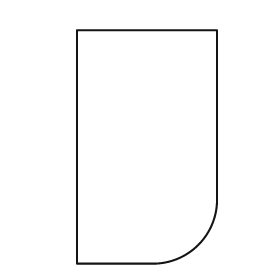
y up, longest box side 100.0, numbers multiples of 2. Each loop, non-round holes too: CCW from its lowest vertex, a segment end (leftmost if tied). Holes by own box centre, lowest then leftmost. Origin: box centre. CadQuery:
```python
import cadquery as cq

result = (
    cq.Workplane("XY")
    .moveTo(-30.0, -50.0)
    .lineTo(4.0, -50.0)
    .threePointArc((22.0, -42.0), (30.0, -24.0))
    .lineTo(30.0, 50.0)
    .lineTo(-30.0, 50.0)
    .close()
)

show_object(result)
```